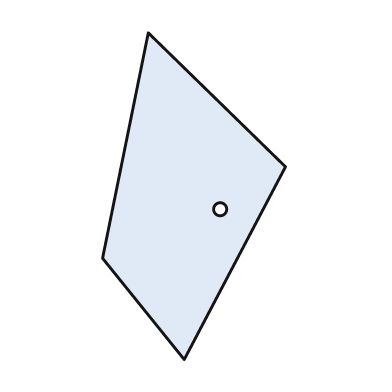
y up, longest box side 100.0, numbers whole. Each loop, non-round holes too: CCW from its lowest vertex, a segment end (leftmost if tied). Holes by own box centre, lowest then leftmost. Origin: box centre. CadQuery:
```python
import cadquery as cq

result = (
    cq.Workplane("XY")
    .moveTo(-3.0, -50.0)
    .lineTo(28.0, 9.0)
    .lineTo(-14.0, 50.0)
    .lineTo(-28.0, -19.0)
    .close()
    .moveTo(8.0, -4.0)
    .circle(2.0)
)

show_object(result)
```